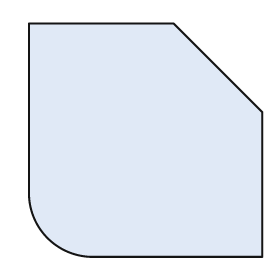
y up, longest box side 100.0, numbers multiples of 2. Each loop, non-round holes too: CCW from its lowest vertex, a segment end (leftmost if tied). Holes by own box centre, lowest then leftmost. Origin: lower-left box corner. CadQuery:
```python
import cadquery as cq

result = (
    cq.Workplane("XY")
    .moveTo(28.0, 0.0)
    .lineTo(100.0, 0.0)
    .lineTo(100.0, 62.0)
    .lineTo(62.0, 100.0)
    .lineTo(0.0, 100.0)
    .lineTo(0.0, 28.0)
    .threePointArc((8.0, 8.0), (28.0, 0.0))
    .close()
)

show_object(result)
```